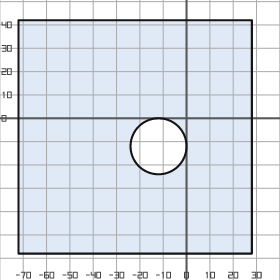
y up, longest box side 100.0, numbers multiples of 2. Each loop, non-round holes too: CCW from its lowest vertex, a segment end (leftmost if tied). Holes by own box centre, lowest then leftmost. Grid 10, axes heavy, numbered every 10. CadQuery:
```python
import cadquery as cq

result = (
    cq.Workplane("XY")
    .moveTo(-72.0, -58.0)
    .lineTo(28.0, -58.0)
    .lineTo(28.0, 42.0)
    .lineTo(-72.0, 42.0)
    .close()
    .moveTo(-12.0, -12.0)
    .circle(12.0)
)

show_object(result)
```